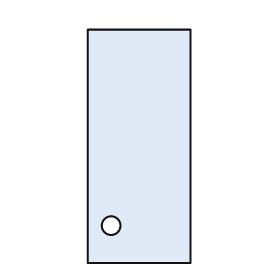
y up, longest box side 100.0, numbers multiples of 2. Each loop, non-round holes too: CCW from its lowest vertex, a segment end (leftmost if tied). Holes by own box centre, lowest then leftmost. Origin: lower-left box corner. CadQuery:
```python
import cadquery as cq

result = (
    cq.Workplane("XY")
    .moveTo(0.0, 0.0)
    .lineTo(44.0, 0.0)
    .lineTo(44.0, 100.0)
    .lineTo(0.0, 100.0)
    .close()
    .moveTo(10.0, 16.0)
    .circle(4.0)
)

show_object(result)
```